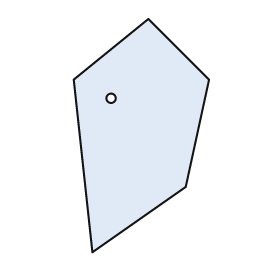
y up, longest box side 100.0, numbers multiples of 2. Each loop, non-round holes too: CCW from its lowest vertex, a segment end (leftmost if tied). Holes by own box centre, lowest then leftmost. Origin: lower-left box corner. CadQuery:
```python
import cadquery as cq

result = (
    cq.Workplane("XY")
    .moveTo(8.0, 0.0)
    .lineTo(48.0, 28.0)
    .lineTo(58.0, 74.0)
    .lineTo(32.0, 100.0)
    .lineTo(0.0, 74.0)
    .close()
    .moveTo(16.0, 66.0)
    .circle(2.0)
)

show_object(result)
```